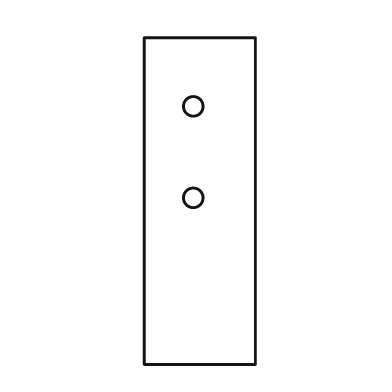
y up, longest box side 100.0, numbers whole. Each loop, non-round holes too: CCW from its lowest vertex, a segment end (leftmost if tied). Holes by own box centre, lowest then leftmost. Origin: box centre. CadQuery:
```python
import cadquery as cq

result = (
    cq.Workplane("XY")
    .moveTo(-17.0, -50.0)
    .lineTo(17.0, -50.0)
    .lineTo(17.0, 50.0)
    .lineTo(-17.0, 50.0)
    .close()
    .moveTo(-2.0, 1.0)
    .circle(3.0)
    .moveTo(-2.0, 29.0)
    .circle(3.0)
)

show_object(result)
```